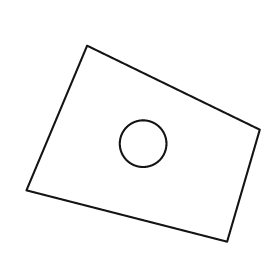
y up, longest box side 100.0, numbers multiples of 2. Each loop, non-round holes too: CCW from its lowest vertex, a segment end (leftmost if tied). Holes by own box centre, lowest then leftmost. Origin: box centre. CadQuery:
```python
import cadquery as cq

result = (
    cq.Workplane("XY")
    .moveTo(36.0, -42.0)
    .lineTo(50.0, 6.0)
    .lineTo(-24.0, 42.0)
    .lineTo(-50.0, -20.0)
    .close()
    .moveTo(0.0, 0.0)
    .circle(10.0)
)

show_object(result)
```